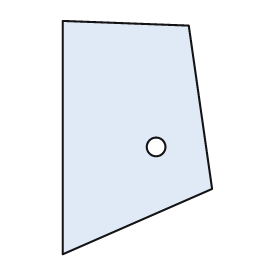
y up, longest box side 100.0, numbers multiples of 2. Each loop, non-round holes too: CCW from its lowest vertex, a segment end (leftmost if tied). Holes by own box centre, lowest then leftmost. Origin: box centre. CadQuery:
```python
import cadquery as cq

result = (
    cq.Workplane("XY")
    .moveTo(-32.0, -50.0)
    .lineTo(32.0, -22.0)
    .lineTo(22.0, 48.0)
    .lineTo(-32.0, 50.0)
    .close()
    .moveTo(8.0, -4.0)
    .circle(4.0)
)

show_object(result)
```